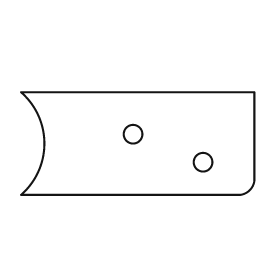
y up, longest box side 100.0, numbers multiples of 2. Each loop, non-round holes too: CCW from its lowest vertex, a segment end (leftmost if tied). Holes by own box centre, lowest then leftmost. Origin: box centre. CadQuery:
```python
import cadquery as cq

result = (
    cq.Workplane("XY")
    .moveTo(-50.0, -22.0)
    .lineTo(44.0, -22.0)
    .threePointArc((48.0, -20.0), (50.0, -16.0))
    .lineTo(50.0, 22.0)
    .lineTo(-50.0, 22.0)
    .threePointArc((-40.0, 0.0), (-50.0, -22.0))
    .close()
    .moveTo(28.0, -8.0)
    .circle(4.0)
    .moveTo(-2.0, 4.0)
    .circle(4.0)
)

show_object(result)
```